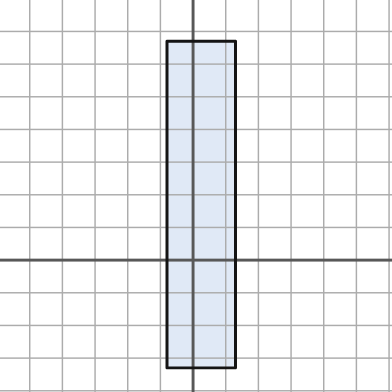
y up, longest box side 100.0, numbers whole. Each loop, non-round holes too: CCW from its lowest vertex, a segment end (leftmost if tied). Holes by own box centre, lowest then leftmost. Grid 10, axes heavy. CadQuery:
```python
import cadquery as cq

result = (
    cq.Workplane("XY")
    .moveTo(-8.0, -33.0)
    .lineTo(13.0, -33.0)
    .lineTo(13.0, 67.0)
    .lineTo(-8.0, 67.0)
    .close()
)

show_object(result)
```